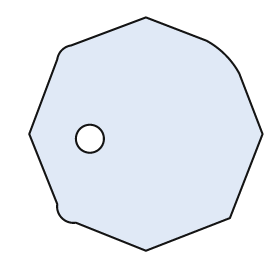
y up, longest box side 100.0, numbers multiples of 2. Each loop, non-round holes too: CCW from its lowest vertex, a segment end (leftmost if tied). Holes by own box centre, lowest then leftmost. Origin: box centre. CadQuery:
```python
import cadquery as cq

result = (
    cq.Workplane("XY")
    .moveTo(0.0, -50.0)
    .lineTo(36.0, -36.0)
    .lineTo(50.0, 0.0)
    .lineTo(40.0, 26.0)
    .threePointArc((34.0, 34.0), (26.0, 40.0))
    .lineTo(0.0, 50.0)
    .lineTo(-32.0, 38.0)
    .threePointArc((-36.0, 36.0), (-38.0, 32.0))
    .lineTo(-50.0, 0.0)
    .lineTo(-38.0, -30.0)
    .threePointArc((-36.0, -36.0), (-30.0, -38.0))
    .close()
    .moveTo(-24.0, -2.0)
    .circle(6.0)
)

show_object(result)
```